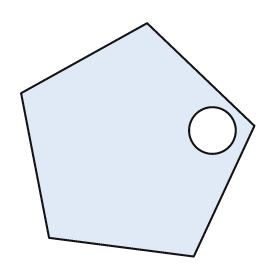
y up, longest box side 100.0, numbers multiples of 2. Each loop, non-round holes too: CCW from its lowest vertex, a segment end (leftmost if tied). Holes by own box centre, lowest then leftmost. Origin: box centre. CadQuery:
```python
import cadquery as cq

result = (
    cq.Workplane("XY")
    .moveTo(24.0, -50.0)
    .lineTo(50.0, 6.0)
    .lineTo(4.0, 50.0)
    .lineTo(-50.0, 20.0)
    .lineTo(-38.0, -42.0)
    .close()
    .moveTo(32.0, 4.0)
    .circle(10.0)
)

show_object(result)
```